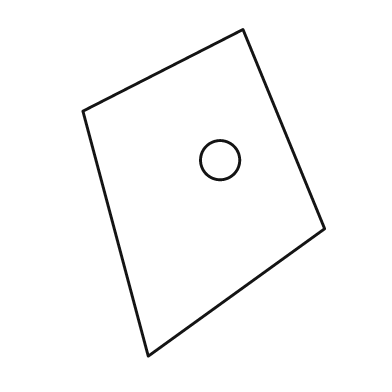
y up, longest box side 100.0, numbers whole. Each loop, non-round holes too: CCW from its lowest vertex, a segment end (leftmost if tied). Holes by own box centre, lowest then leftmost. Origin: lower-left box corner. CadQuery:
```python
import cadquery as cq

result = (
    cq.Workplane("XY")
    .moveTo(20.0, 0.0)
    .lineTo(74.0, 39.0)
    .lineTo(49.0, 100.0)
    .lineTo(0.0, 75.0)
    .close()
    .moveTo(42.0, 60.0)
    .circle(6.0)
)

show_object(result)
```